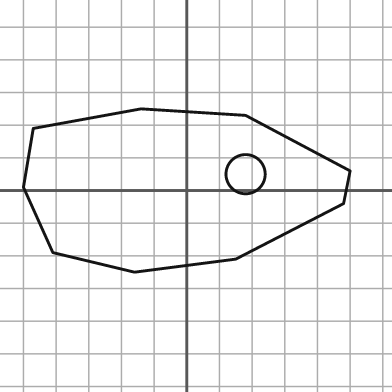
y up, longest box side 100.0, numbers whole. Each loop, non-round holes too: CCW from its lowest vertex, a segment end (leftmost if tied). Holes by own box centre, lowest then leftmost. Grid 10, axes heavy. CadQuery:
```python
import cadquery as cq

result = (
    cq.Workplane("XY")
    .moveTo(-16.0, -25.0)
    .lineTo(15.0, -21.0)
    .lineTo(48.0, -4.0)
    .lineTo(50.0, 6.0)
    .lineTo(18.0, 23.0)
    .lineTo(-14.0, 25.0)
    .lineTo(-47.0, 19.0)
    .lineTo(-50.0, 1.0)
    .lineTo(-41.0, -19.0)
    .close()
    .moveTo(18.0, 5.0)
    .circle(6.0)
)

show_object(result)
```